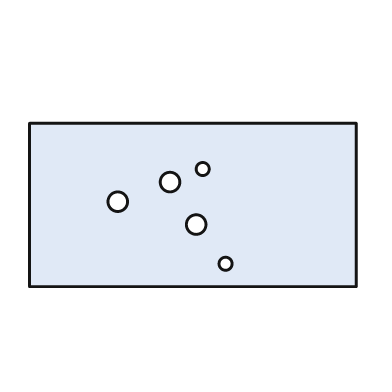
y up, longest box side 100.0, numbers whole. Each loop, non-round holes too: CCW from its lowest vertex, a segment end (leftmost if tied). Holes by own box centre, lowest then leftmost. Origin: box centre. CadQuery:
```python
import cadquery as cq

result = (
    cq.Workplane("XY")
    .moveTo(-50.0, -25.0)
    .lineTo(50.0, -25.0)
    .lineTo(50.0, 25.0)
    .lineTo(-50.0, 25.0)
    .close()
    .moveTo(10.0, -18.0)
    .circle(2.0)
    .moveTo(1.0, -6.0)
    .circle(3.0)
    .moveTo(-23.0, 1.0)
    .circle(3.0)
    .moveTo(-7.0, 7.0)
    .circle(3.0)
    .moveTo(3.0, 11.0)
    .circle(2.0)
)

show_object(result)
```